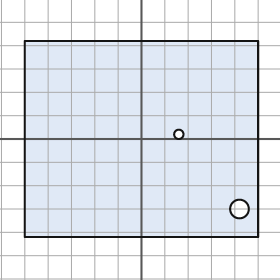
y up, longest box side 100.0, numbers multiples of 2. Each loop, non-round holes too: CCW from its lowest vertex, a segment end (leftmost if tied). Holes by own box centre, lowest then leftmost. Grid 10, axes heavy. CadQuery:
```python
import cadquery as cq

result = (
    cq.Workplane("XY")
    .moveTo(-50.0, -42.0)
    .lineTo(50.0, -42.0)
    .lineTo(50.0, 42.0)
    .lineTo(-50.0, 42.0)
    .close()
    .moveTo(42.0, -30.0)
    .circle(4.0)
    .moveTo(16.0, 2.0)
    .circle(2.0)
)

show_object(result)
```